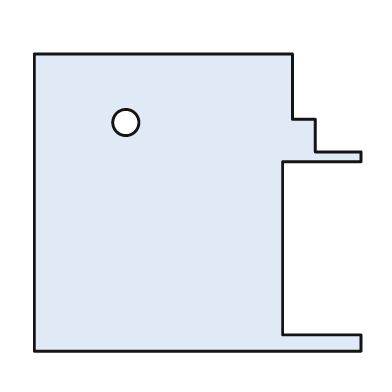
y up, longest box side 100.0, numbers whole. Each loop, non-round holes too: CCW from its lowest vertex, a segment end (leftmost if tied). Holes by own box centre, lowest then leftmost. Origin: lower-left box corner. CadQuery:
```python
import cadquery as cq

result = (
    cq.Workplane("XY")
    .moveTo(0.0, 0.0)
    .lineTo(100.0, 0.0)
    .lineTo(100.0, 5.0)
    .lineTo(76.0, 5.0)
    .lineTo(76.0, 58.0)
    .lineTo(100.0, 58.0)
    .lineTo(100.0, 61.0)
    .lineTo(86.0, 61.0)
    .lineTo(86.0, 71.0)
    .lineTo(79.0, 71.0)
    .lineTo(79.0, 91.0)
    .lineTo(0.0, 91.0)
    .close()
    .moveTo(28.0, 70.0)
    .circle(4.0)
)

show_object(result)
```